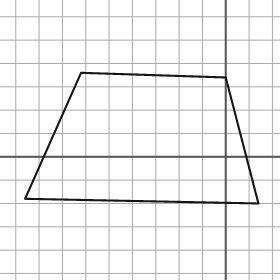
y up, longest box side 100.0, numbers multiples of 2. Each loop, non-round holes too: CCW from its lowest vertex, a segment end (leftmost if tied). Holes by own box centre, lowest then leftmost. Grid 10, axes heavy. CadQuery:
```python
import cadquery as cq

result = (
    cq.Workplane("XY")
    .moveTo(14.0, -20.0)
    .lineTo(0.0, 34.0)
    .lineTo(-62.0, 36.0)
    .lineTo(-86.0, -18.0)
    .close()
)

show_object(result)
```